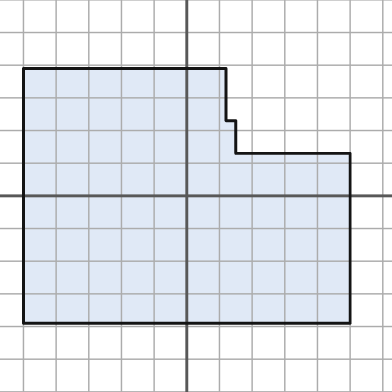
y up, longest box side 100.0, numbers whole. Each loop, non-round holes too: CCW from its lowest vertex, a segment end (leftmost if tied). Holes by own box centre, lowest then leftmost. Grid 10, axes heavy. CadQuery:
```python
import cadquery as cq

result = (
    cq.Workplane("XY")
    .moveTo(-50.0, -39.0)
    .lineTo(50.0, -39.0)
    .lineTo(50.0, 13.0)
    .lineTo(15.0, 13.0)
    .lineTo(15.0, 23.0)
    .lineTo(12.0, 23.0)
    .lineTo(12.0, 39.0)
    .lineTo(-50.0, 39.0)
    .close()
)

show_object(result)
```